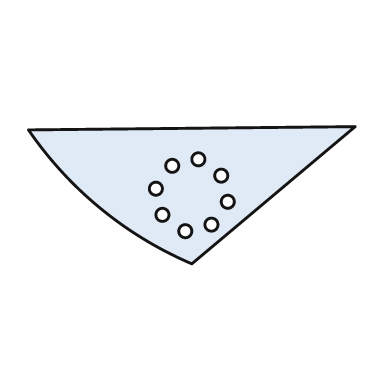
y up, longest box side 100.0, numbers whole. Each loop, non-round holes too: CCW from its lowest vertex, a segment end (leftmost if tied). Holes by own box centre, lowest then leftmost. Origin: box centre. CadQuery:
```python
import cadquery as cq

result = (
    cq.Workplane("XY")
    .moveTo(0.0, -21.0)
    .lineTo(50.0, 21.0)
    .lineTo(-50.0, 20.0)
    .threePointArc((-28.0, -4.0), (0.0, -21.0))
    .close()
    .moveTo(-2.0, -11.0)
    .circle(2.0)
    .moveTo(6.0, -9.0)
    .circle(2.0)
    .moveTo(-9.0, -6.0)
    .circle(2.0)
    .moveTo(11.0, -2.0)
    .circle(2.0)
    .moveTo(-11.0, 2.0)
    .circle(2.0)
    .moveTo(9.0, 6.0)
    .circle(2.0)
    .moveTo(-6.0, 9.0)
    .circle(2.0)
    .moveTo(2.0, 11.0)
    .circle(2.0)
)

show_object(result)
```